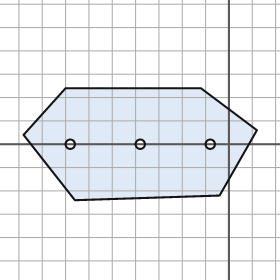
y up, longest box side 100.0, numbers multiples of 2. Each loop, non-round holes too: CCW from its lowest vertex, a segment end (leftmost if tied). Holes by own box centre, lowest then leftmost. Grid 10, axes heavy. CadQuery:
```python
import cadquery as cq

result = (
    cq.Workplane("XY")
    .moveTo(-66.0, -24.0)
    .lineTo(-4.0, -22.0)
    .lineTo(12.0, 6.0)
    .lineTo(-12.0, 24.0)
    .lineTo(-70.0, 24.0)
    .lineTo(-88.0, 4.0)
    .close()
    .moveTo(-68.0, 0.0)
    .circle(2.0)
    .moveTo(-38.0, 0.0)
    .circle(2.0)
    .moveTo(-8.0, 0.0)
    .circle(2.0)
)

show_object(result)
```